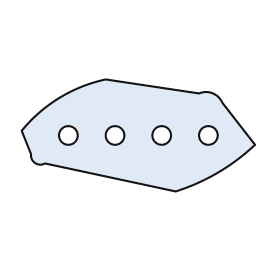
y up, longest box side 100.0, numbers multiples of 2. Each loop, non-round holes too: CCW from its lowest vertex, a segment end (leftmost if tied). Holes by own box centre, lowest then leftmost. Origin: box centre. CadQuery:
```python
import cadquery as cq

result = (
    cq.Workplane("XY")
    .moveTo(16.0, -24.0)
    .threePointArc((34.0, -16.0), (50.0, -4.0))
    .lineTo(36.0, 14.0)
    .threePointArc((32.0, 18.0), (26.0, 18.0))
    .lineTo(-14.0, 24.0)
    .threePointArc((-34.0, 16.0), (-50.0, 2.0))
    .lineTo(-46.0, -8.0)
    .threePointArc((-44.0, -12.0), (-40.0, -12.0))
    .close()
    .moveTo(-30.0, 0.0)
    .circle(4.0)
    .moveTo(-10.0, 0.0)
    .circle(4.0)
    .moveTo(10.0, 0.0)
    .circle(4.0)
    .moveTo(30.0, 0.0)
    .circle(4.0)
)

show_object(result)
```